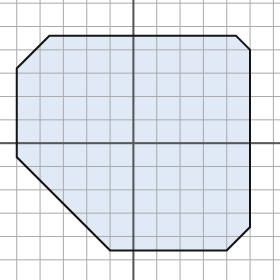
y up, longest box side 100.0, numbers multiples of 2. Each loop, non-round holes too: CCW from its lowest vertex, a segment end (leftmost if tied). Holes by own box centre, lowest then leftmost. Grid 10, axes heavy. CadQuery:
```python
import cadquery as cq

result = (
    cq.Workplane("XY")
    .moveTo(-10.0, -46.0)
    .lineTo(40.0, -46.0)
    .lineTo(50.0, -36.0)
    .lineTo(50.0, 40.0)
    .lineTo(44.0, 46.0)
    .lineTo(-36.0, 46.0)
    .lineTo(-50.0, 32.0)
    .lineTo(-50.0, -6.0)
    .close()
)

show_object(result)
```